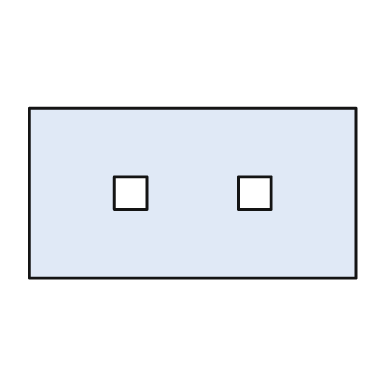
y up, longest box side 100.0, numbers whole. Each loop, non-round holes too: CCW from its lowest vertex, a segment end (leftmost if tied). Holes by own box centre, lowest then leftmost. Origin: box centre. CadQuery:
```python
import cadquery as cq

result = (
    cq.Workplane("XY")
    .moveTo(-50.0, -26.0)
    .lineTo(50.0, -26.0)
    .lineTo(50.0, 26.0)
    .lineTo(-50.0, 26.0)
    .close()
    .moveTo(-24.0, -5.0)
    .lineTo(-14.0, -5.0)
    .lineTo(-14.0, 5.0)
    .lineTo(-24.0, 5.0)
    .close()
    .moveTo(14.0, -5.0)
    .lineTo(24.0, -5.0)
    .lineTo(24.0, 5.0)
    .lineTo(14.0, 5.0)
    .close()
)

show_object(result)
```